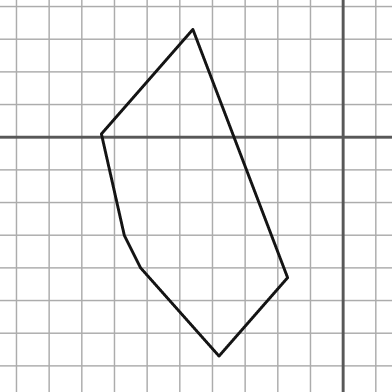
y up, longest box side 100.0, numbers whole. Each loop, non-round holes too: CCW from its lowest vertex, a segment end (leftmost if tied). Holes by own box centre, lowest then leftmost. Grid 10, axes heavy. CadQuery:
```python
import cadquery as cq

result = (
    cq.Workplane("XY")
    .moveTo(-38.0, -67.0)
    .lineTo(-17.0, -43.0)
    .lineTo(-46.0, 33.0)
    .lineTo(-74.0, 1.0)
    .lineTo(-67.0, -30.0)
    .lineTo(-62.0, -40.0)
    .close()
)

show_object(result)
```